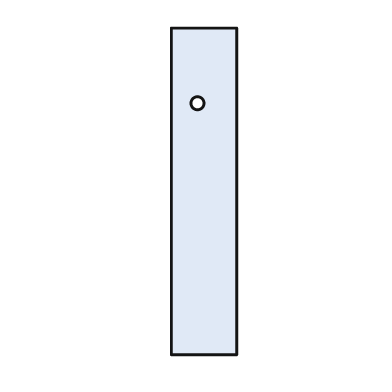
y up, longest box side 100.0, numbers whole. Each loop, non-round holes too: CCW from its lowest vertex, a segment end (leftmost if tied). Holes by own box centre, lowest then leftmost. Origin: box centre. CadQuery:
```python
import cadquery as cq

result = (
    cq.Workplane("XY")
    .moveTo(-10.0, -50.0)
    .lineTo(10.0, -50.0)
    .lineTo(10.0, 50.0)
    .lineTo(-10.0, 50.0)
    .close()
    .moveTo(-2.0, 27.0)
    .circle(2.0)
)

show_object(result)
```